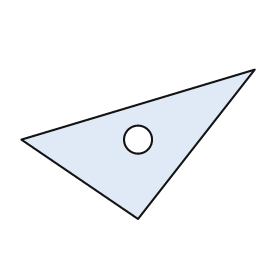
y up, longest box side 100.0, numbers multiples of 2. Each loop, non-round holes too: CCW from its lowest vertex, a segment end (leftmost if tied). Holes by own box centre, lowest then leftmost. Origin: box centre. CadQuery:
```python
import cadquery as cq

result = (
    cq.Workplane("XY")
    .moveTo(0.0, -32.0)
    .lineTo(50.0, 32.0)
    .lineTo(-50.0, 2.0)
    .close()
    .moveTo(0.0, 2.0)
    .circle(6.0)
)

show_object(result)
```